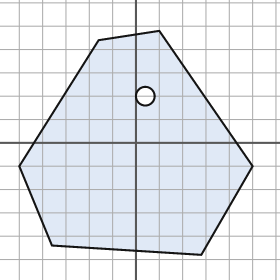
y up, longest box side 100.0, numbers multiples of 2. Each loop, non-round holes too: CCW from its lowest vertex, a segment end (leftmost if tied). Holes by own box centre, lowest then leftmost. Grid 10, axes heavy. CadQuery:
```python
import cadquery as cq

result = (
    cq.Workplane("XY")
    .moveTo(28.0, -48.0)
    .lineTo(50.0, -10.0)
    .lineTo(10.0, 48.0)
    .lineTo(-16.0, 44.0)
    .lineTo(-50.0, -10.0)
    .lineTo(-36.0, -44.0)
    .close()
    .moveTo(4.0, 20.0)
    .circle(4.0)
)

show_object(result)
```